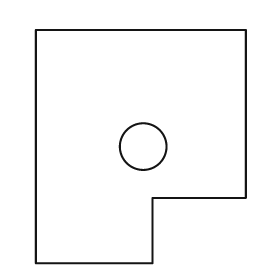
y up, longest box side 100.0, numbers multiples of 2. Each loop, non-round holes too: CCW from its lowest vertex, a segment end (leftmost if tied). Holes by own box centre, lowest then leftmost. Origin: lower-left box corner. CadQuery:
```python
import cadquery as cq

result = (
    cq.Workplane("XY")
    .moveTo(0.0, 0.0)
    .lineTo(50.0, 0.0)
    .lineTo(50.0, 28.0)
    .lineTo(90.0, 28.0)
    .lineTo(90.0, 100.0)
    .lineTo(0.0, 100.0)
    .close()
    .moveTo(46.0, 50.0)
    .circle(10.0)
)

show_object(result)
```